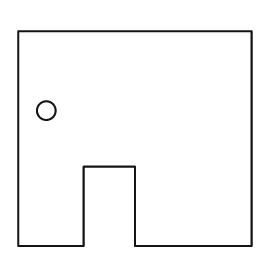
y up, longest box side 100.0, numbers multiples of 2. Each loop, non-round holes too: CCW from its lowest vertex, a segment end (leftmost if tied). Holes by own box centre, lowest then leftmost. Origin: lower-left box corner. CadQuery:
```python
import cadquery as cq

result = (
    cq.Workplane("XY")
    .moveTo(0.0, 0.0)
    .lineTo(28.0, 0.0)
    .lineTo(28.0, 34.0)
    .lineTo(50.0, 34.0)
    .lineTo(50.0, 0.0)
    .lineTo(100.0, 0.0)
    .lineTo(100.0, 92.0)
    .lineTo(0.0, 92.0)
    .close()
    .moveTo(12.0, 58.0)
    .circle(4.0)
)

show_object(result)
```